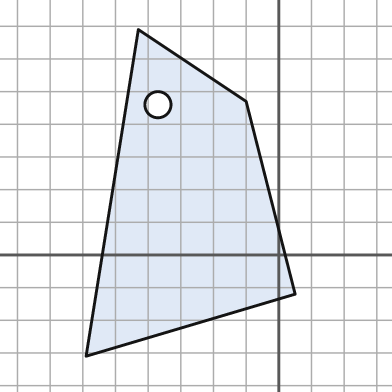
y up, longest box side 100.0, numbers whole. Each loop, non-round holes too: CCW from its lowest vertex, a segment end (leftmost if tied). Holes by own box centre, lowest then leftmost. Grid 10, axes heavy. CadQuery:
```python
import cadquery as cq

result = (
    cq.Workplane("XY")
    .moveTo(-59.0, -31.0)
    .lineTo(5.0, -12.0)
    .lineTo(-10.0, 47.0)
    .lineTo(-43.0, 69.0)
    .close()
    .moveTo(-37.0, 46.0)
    .circle(4.0)
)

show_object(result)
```